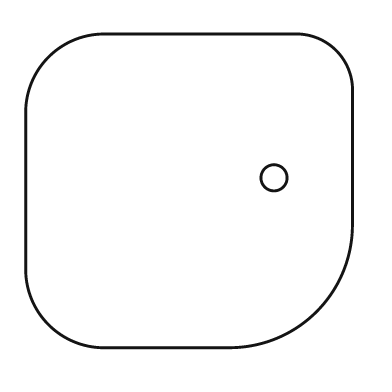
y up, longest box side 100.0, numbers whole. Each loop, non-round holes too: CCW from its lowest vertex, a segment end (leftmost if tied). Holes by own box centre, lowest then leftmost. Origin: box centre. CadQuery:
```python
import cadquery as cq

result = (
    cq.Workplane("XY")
    .moveTo(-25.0, -48.0)
    .lineTo(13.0, -48.0)
    .threePointArc((39.0, -37.0), (50.0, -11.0))
    .lineTo(50.0, 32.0)
    .threePointArc((45.0, 43.0), (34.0, 48.0))
    .lineTo(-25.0, 48.0)
    .threePointArc((-43.0, 41.0), (-50.0, 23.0))
    .lineTo(-50.0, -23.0)
    .threePointArc((-43.0, -41.0), (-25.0, -48.0))
    .close()
    .moveTo(26.0, 4.0)
    .circle(4.0)
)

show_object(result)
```